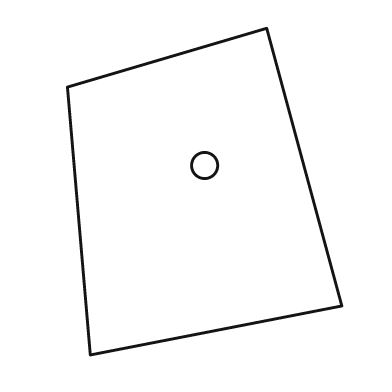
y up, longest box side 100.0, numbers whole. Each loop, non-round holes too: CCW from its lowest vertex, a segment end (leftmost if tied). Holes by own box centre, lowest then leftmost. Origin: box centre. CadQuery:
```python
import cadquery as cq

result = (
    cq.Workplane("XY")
    .moveTo(-35.0, -50.0)
    .lineTo(42.0, -35.0)
    .lineTo(19.0, 50.0)
    .lineTo(-42.0, 32.0)
    .close()
    .moveTo(0.0, 8.0)
    .circle(4.0)
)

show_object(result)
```